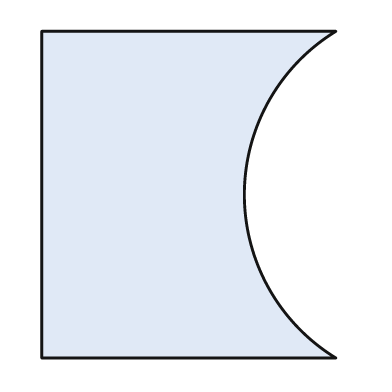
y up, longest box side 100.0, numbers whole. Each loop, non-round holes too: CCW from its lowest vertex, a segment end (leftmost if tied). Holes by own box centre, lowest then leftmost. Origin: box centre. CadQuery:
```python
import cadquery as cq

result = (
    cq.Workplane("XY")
    .moveTo(-45.0, -50.0)
    .lineTo(45.0, -50.0)
    .threePointArc((17.0, 0.0), (45.0, 50.0))
    .lineTo(-45.0, 50.0)
    .close()
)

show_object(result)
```